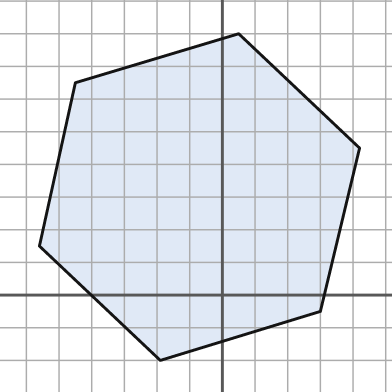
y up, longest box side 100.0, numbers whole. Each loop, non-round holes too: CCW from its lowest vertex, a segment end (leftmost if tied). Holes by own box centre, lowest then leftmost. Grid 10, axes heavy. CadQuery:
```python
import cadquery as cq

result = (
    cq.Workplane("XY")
    .moveTo(-19.0, -20.0)
    .lineTo(30.0, -5.0)
    .lineTo(42.0, 45.0)
    .lineTo(5.0, 80.0)
    .lineTo(-45.0, 65.0)
    .lineTo(-56.0, 15.0)
    .close()
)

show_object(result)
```